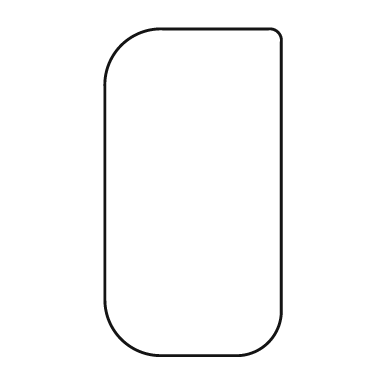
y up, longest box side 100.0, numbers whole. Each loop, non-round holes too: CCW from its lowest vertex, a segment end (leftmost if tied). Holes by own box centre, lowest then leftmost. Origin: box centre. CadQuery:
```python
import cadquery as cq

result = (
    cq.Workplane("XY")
    .moveTo(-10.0, -50.0)
    .lineTo(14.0, -50.0)
    .threePointArc((23.0, -46.0), (27.0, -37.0))
    .lineTo(27.0, 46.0)
    .threePointArc((26.0, 49.0), (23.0, 50.0))
    .lineTo(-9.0, 50.0)
    .threePointArc((-22.0, 45.0), (-27.0, 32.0))
    .lineTo(-27.0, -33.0)
    .threePointArc((-22.0, -45.0), (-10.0, -50.0))
    .close()
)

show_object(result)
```